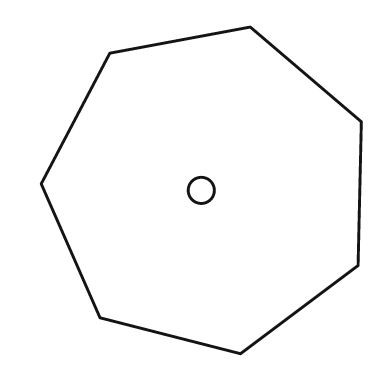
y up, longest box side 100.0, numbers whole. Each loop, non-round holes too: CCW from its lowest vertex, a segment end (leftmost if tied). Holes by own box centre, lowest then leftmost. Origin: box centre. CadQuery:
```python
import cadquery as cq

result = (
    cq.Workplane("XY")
    .moveTo(12.0, -50.0)
    .lineTo(48.0, -23.0)
    .lineTo(49.0, 21.0)
    .lineTo(15.0, 50.0)
    .lineTo(-28.0, 42.0)
    .lineTo(-49.0, 2.0)
    .lineTo(-31.0, -39.0)
    .close()
    .moveTo(0.0, 0.0)
    .circle(4.0)
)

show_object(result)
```